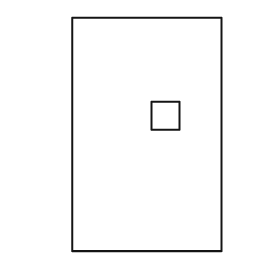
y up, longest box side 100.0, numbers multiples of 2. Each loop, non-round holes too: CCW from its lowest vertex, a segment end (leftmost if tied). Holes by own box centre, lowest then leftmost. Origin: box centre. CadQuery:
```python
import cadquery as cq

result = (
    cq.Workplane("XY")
    .moveTo(-32.0, -50.0)
    .lineTo(32.0, -50.0)
    .lineTo(32.0, 50.0)
    .lineTo(-32.0, 50.0)
    .close()
    .moveTo(2.0, 2.0)
    .lineTo(14.0, 2.0)
    .lineTo(14.0, 14.0)
    .lineTo(2.0, 14.0)
    .close()
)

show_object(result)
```